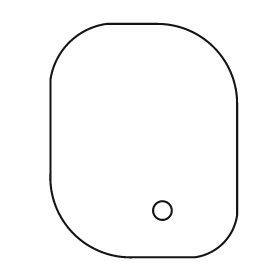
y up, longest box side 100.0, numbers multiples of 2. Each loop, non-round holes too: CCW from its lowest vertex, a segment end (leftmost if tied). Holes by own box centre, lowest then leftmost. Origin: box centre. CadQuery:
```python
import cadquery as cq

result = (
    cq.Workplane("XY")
    .moveTo(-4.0, -50.0)
    .lineTo(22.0, -50.0)
    .threePointArc((34.0, -44.0), (40.0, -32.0))
    .lineTo(40.0, 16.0)
    .threePointArc((30.0, 40.0), (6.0, 50.0))
    .lineTo(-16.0, 50.0)
    .threePointArc((-32.0, 42.0), (-40.0, 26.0))
    .lineTo(-40.0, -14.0)
    .threePointArc((-30.0, -40.0), (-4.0, -50.0))
    .close()
    .moveTo(8.0, -30.0)
    .circle(4.0)
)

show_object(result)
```